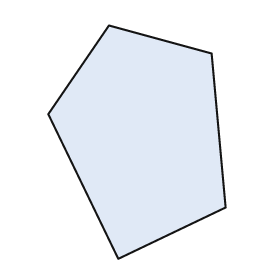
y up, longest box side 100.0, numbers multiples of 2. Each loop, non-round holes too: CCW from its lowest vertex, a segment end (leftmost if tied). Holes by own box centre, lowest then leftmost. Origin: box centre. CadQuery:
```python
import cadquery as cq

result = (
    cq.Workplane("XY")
    .moveTo(-8.0, -50.0)
    .lineTo(38.0, -28.0)
    .lineTo(32.0, 38.0)
    .lineTo(-12.0, 50.0)
    .lineTo(-38.0, 12.0)
    .close()
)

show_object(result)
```